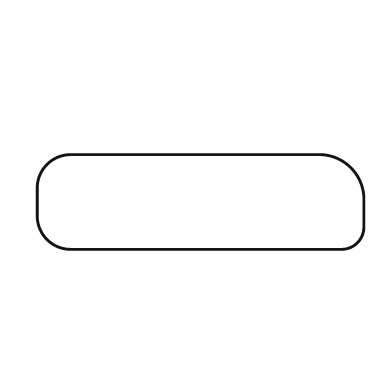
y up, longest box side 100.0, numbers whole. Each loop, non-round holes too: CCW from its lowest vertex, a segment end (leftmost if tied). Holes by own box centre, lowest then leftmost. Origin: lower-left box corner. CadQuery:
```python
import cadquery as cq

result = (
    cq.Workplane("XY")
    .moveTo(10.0, 0.0)
    .lineTo(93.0, 0.0)
    .threePointArc((98.0, 2.0), (100.0, 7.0))
    .lineTo(100.0, 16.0)
    .threePointArc((96.0, 25.0), (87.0, 29.0))
    .lineTo(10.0, 29.0)
    .threePointArc((3.0, 26.0), (0.0, 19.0))
    .lineTo(0.0, 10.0)
    .threePointArc((3.0, 3.0), (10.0, 0.0))
    .close()
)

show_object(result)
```